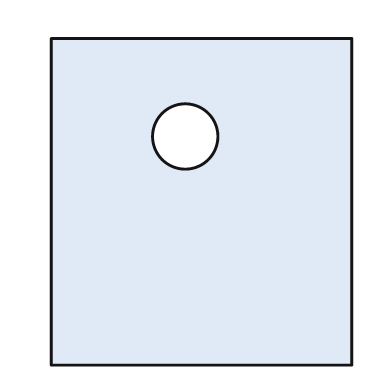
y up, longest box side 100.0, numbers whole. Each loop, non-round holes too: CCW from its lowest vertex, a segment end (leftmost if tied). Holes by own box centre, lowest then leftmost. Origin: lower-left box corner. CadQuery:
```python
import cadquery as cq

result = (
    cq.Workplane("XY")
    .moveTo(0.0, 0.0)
    .lineTo(92.0, 0.0)
    .lineTo(92.0, 100.0)
    .lineTo(0.0, 100.0)
    .close()
    .moveTo(41.0, 70.0)
    .circle(10.0)
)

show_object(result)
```